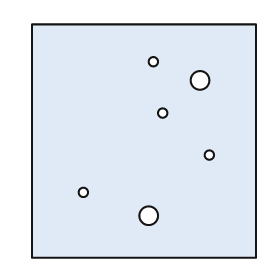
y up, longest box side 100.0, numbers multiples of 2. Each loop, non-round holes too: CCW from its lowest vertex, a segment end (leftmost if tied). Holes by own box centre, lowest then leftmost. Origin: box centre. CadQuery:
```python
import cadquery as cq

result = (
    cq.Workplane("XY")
    .moveTo(-48.0, -50.0)
    .lineTo(48.0, -50.0)
    .lineTo(48.0, 50.0)
    .lineTo(-48.0, 50.0)
    .close()
    .moveTo(2.0, -32.0)
    .circle(4.0)
    .moveTo(-26.0, -22.0)
    .circle(2.0)
    .moveTo(28.0, -6.0)
    .circle(2.0)
    .moveTo(8.0, 12.0)
    .circle(2.0)
    .moveTo(24.0, 26.0)
    .circle(4.0)
    .moveTo(4.0, 34.0)
    .circle(2.0)
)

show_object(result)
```